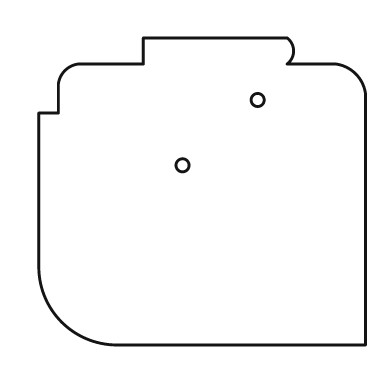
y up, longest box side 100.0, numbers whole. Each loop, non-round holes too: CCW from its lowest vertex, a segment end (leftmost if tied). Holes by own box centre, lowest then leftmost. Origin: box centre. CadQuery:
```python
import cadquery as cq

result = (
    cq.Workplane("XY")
    .moveTo(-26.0, -47.0)
    .lineTo(50.0, -47.0)
    .lineTo(50.0, 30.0)
    .threePointArc((47.0, 36.0), (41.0, 39.0))
    .lineTo(26.0, 39.0)
    .threePointArc((28.0, 43.0), (26.0, 47.0))
    .lineTo(-18.0, 47.0)
    .lineTo(-18.0, 39.0)
    .lineTo(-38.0, 39.0)
    .threePointArc((-42.0, 37.0), (-44.0, 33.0))
    .lineTo(-44.0, 24.0)
    .lineTo(-50.0, 24.0)
    .lineTo(-50.0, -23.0)
    .threePointArc((-43.0, -40.0), (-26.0, -47.0))
    .close()
    .moveTo(-6.0, 8.0)
    .circle(2.0)
    .moveTo(17.0, 28.0)
    .circle(2.0)
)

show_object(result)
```